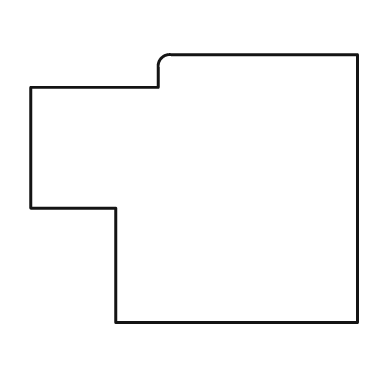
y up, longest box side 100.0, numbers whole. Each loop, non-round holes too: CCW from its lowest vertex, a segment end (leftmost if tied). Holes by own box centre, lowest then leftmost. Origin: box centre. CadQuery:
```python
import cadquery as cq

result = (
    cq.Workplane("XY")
    .moveTo(-24.0, -41.0)
    .lineTo(50.0, -41.0)
    .lineTo(50.0, 41.0)
    .lineTo(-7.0, 41.0)
    .threePointArc((-10.0, 40.0), (-11.0, 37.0))
    .lineTo(-11.0, 31.0)
    .lineTo(-50.0, 31.0)
    .lineTo(-50.0, -6.0)
    .lineTo(-24.0, -6.0)
    .close()
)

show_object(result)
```